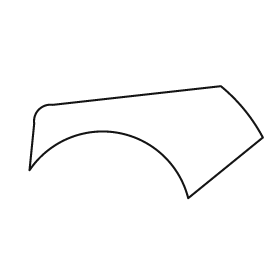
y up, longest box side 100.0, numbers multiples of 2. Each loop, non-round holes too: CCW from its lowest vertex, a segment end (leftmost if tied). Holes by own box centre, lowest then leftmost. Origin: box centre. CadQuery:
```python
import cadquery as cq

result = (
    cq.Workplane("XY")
    .moveTo(18.0, -24.0)
    .lineTo(50.0, 2.0)
    .threePointArc((42.0, 14.0), (32.0, 24.0))
    .lineTo(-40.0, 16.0)
    .threePointArc((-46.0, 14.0), (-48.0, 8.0))
    .lineTo(-50.0, -12.0)
    .threePointArc((-12.0, 4.0), (18.0, -24.0))
    .close()
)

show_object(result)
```